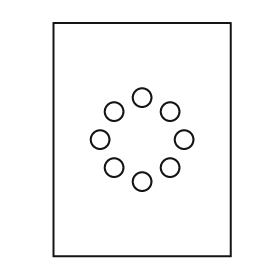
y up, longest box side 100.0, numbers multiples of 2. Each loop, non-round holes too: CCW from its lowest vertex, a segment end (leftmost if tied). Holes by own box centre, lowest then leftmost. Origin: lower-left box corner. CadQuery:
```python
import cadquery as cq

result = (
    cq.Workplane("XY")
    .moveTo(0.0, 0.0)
    .lineTo(76.0, 0.0)
    .lineTo(76.0, 100.0)
    .lineTo(0.0, 100.0)
    .close()
    .moveTo(38.0, 32.0)
    .circle(4.0)
    .moveTo(26.0, 38.0)
    .circle(4.0)
    .moveTo(50.0, 38.0)
    .circle(4.0)
    .moveTo(20.0, 50.0)
    .circle(4.0)
    .moveTo(56.0, 50.0)
    .circle(4.0)
    .moveTo(26.0, 62.0)
    .circle(4.0)
    .moveTo(50.0, 62.0)
    .circle(4.0)
    .moveTo(38.0, 68.0)
    .circle(4.0)
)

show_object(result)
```